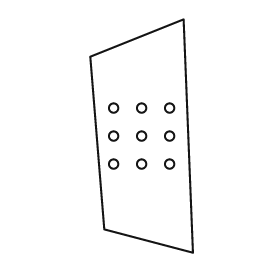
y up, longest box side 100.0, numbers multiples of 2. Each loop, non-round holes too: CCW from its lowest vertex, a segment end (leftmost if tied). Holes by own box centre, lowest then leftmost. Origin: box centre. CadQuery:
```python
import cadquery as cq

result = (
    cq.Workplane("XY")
    .moveTo(22.0, -50.0)
    .lineTo(18.0, 50.0)
    .lineTo(-22.0, 34.0)
    .lineTo(-16.0, -40.0)
    .close()
    .moveTo(-12.0, -12.0)
    .circle(2.0)
    .moveTo(0.0, -12.0)
    .circle(2.0)
    .moveTo(12.0, -12.0)
    .circle(2.0)
    .moveTo(-12.0, 0.0)
    .circle(2.0)
    .moveTo(0.0, 0.0)
    .circle(2.0)
    .moveTo(12.0, 0.0)
    .circle(2.0)
    .moveTo(-12.0, 12.0)
    .circle(2.0)
    .moveTo(0.0, 12.0)
    .circle(2.0)
    .moveTo(12.0, 12.0)
    .circle(2.0)
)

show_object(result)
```